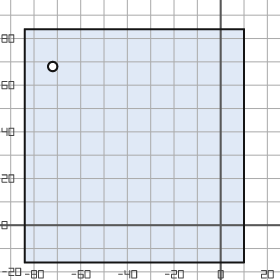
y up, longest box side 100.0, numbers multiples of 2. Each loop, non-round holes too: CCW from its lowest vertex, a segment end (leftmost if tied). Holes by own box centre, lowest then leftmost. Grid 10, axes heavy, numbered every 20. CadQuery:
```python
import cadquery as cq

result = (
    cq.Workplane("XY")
    .moveTo(-84.0, -16.0)
    .lineTo(10.0, -16.0)
    .lineTo(10.0, 84.0)
    .lineTo(-84.0, 84.0)
    .close()
    .moveTo(-72.0, 68.0)
    .circle(2.0)
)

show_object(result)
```